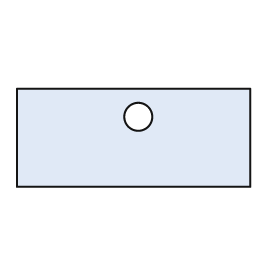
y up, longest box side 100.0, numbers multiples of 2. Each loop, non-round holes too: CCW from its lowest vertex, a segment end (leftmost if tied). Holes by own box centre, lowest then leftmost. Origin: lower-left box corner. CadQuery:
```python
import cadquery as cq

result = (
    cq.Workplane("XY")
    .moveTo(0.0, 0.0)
    .lineTo(100.0, 0.0)
    .lineTo(100.0, 42.0)
    .lineTo(0.0, 42.0)
    .close()
    .moveTo(52.0, 30.0)
    .circle(6.0)
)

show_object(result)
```